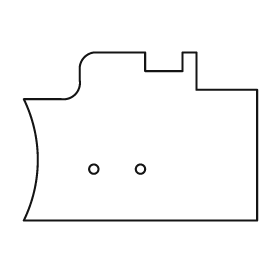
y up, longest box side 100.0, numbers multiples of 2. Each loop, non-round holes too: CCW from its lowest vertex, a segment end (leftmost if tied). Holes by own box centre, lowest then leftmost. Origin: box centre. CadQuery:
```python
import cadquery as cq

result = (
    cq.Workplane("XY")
    .moveTo(-50.0, -36.0)
    .lineTo(50.0, -36.0)
    .lineTo(50.0, 20.0)
    .lineTo(24.0, 20.0)
    .lineTo(24.0, 36.0)
    .lineTo(18.0, 36.0)
    .lineTo(18.0, 28.0)
    .lineTo(2.0, 28.0)
    .lineTo(2.0, 36.0)
    .lineTo(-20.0, 36.0)
    .threePointArc((-24.0, 34.0), (-26.0, 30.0))
    .lineTo(-26.0, 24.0)
    .threePointArc((-28.0, 18.0), (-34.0, 16.0))
    .lineTo(-50.0, 16.0)
    .threePointArc((-44.0, -10.0), (-50.0, -36.0))
    .close()
    .moveTo(-20.0, -14.0)
    .circle(2.0)
    .moveTo(0.0, -14.0)
    .circle(2.0)
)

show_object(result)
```